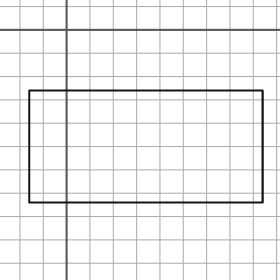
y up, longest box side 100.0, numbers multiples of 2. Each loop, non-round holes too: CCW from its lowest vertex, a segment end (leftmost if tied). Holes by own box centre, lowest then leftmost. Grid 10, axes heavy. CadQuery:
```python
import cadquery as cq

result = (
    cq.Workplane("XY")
    .moveTo(-16.0, -74.0)
    .lineTo(84.0, -74.0)
    .lineTo(84.0, -26.0)
    .lineTo(-16.0, -26.0)
    .close()
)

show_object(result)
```